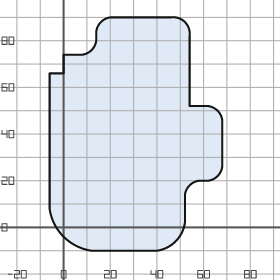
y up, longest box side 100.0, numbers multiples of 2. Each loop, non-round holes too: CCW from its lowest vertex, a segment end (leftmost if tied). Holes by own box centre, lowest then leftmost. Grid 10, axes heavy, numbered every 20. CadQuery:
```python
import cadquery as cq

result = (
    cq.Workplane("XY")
    .moveTo(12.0, -10.0)
    .lineTo(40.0, -10.0)
    .threePointArc((48.0, -6.0), (52.0, 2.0))
    .lineTo(52.0, 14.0)
    .threePointArc((54.0, 18.0), (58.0, 20.0))
    .lineTo(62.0, 20.0)
    .threePointArc((66.0, 22.0), (68.0, 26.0))
    .lineTo(68.0, 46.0)
    .threePointArc((66.0, 50.0), (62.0, 52.0))
    .lineTo(54.0, 52.0)
    .lineTo(54.0, 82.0)
    .threePointArc((52.0, 88.0), (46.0, 90.0))
    .lineTo(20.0, 90.0)
    .threePointArc((16.0, 88.0), (14.0, 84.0))
    .lineTo(14.0, 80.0)
    .threePointArc((12.0, 76.0), (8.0, 74.0))
    .lineTo(0.0, 74.0)
    .lineTo(0.0, 66.0)
    .lineTo(-6.0, 66.0)
    .lineTo(-6.0, 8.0)
    .threePointArc((0.0, -4.0), (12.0, -10.0))
    .close()
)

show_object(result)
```